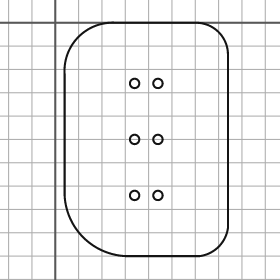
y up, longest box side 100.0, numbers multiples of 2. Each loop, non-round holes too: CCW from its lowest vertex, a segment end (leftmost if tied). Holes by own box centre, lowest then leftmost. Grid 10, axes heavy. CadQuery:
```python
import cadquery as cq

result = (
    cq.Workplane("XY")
    .moveTo(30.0, -100.0)
    .lineTo(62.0, -100.0)
    .threePointArc((70.0, -96.0), (74.0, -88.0))
    .lineTo(74.0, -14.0)
    .threePointArc((70.0, -4.0), (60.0, 0.0))
    .lineTo(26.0, 0.0)
    .threePointArc((10.0, -6.0), (4.0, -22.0))
    .lineTo(4.0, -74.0)
    .threePointArc((12.0, -92.0), (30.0, -100.0))
    .close()
    .moveTo(34.0, -74.0)
    .circle(2.0)
    .moveTo(44.0, -74.0)
    .circle(2.0)
    .moveTo(34.0, -50.0)
    .circle(2.0)
    .moveTo(44.0, -50.0)
    .circle(2.0)
    .moveTo(34.0, -26.0)
    .circle(2.0)
    .moveTo(44.0, -26.0)
    .circle(2.0)
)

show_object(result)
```